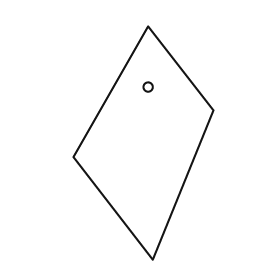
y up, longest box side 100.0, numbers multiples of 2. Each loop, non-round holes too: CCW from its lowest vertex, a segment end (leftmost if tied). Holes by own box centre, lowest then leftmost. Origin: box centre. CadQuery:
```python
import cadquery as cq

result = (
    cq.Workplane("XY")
    .moveTo(4.0, -50.0)
    .lineTo(30.0, 14.0)
    .lineTo(2.0, 50.0)
    .lineTo(-30.0, -6.0)
    .close()
    .moveTo(2.0, 24.0)
    .circle(2.0)
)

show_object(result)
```